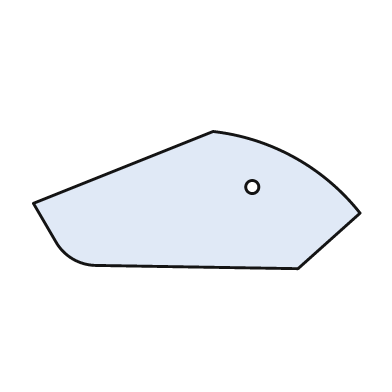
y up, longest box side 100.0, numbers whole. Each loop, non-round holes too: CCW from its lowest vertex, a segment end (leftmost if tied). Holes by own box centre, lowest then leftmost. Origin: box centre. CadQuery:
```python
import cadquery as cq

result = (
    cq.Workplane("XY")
    .moveTo(31.0, -21.0)
    .lineTo(50.0, -4.0)
    .threePointArc((30.0, 13.0), (5.0, 21.0))
    .lineTo(-50.0, -1.0)
    .lineTo(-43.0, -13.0)
    .threePointArc((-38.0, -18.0), (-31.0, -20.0))
    .close()
    .moveTo(17.0, 4.0)
    .circle(2.0)
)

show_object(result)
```